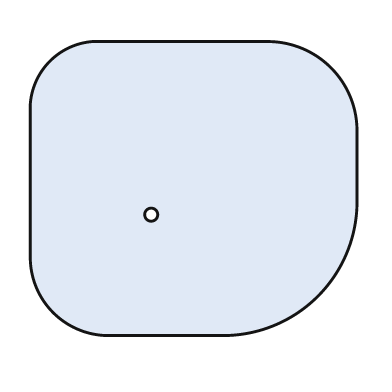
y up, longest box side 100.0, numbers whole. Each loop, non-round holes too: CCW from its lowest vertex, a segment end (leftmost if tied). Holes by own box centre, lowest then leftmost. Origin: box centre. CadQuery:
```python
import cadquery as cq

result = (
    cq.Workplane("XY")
    .moveTo(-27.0, -45.0)
    .lineTo(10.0, -45.0)
    .threePointArc((38.0, -33.0), (50.0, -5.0))
    .lineTo(50.0, 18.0)
    .threePointArc((42.0, 37.0), (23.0, 45.0))
    .lineTo(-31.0, 45.0)
    .threePointArc((-44.0, 39.0), (-50.0, 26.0))
    .lineTo(-50.0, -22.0)
    .threePointArc((-43.0, -38.0), (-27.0, -45.0))
    .close()
    .moveTo(-13.0, -8.0)
    .circle(2.0)
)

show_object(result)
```